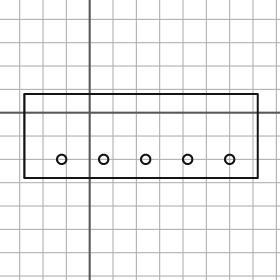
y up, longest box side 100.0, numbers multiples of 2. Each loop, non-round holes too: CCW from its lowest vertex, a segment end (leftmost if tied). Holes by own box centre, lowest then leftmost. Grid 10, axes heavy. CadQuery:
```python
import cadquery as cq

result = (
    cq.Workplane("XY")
    .moveTo(-28.0, -28.0)
    .lineTo(72.0, -28.0)
    .lineTo(72.0, 8.0)
    .lineTo(-28.0, 8.0)
    .close()
    .moveTo(-12.0, -20.0)
    .circle(2.0)
    .moveTo(6.0, -20.0)
    .circle(2.0)
    .moveTo(24.0, -20.0)
    .circle(2.0)
    .moveTo(42.0, -20.0)
    .circle(2.0)
    .moveTo(60.0, -20.0)
    .circle(2.0)
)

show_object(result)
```